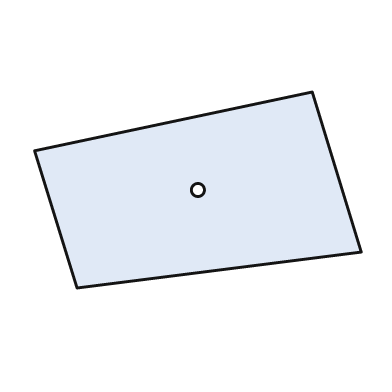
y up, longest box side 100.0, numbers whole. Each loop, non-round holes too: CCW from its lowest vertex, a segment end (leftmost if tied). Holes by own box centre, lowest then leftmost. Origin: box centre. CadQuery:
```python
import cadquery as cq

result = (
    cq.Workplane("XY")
    .moveTo(-37.0, -30.0)
    .lineTo(50.0, -19.0)
    .lineTo(35.0, 30.0)
    .lineTo(-50.0, 12.0)
    .close()
    .moveTo(0.0, 0.0)
    .circle(2.0)
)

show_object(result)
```